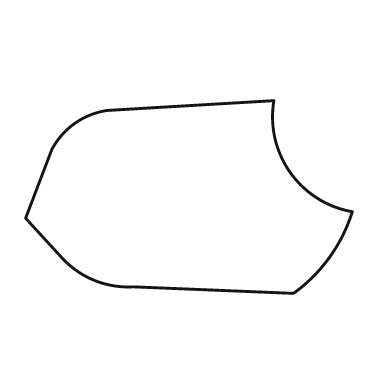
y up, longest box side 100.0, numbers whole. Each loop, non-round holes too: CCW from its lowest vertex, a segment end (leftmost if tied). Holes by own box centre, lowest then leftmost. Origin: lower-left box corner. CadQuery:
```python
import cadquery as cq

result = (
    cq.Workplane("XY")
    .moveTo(82.0, 0.0)
    .threePointArc((93.0, 11.0), (100.0, 25.0))
    .threePointArc((81.0, 37.0), (76.0, 59.0))
    .lineTo(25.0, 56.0)
    .threePointArc((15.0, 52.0), (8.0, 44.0))
    .lineTo(0.0, 23.0)
    .lineTo(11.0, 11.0)
    .threePointArc((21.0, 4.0), (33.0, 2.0))
    .close()
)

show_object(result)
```